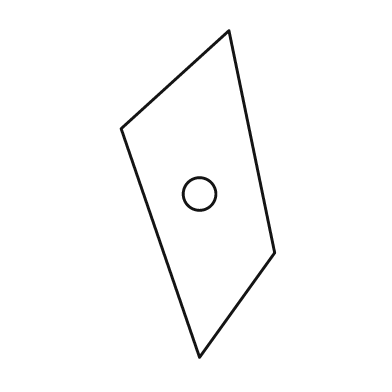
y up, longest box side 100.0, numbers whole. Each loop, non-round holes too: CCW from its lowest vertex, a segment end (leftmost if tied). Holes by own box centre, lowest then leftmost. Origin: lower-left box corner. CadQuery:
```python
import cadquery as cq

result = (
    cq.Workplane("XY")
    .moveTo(24.0, 0.0)
    .lineTo(47.0, 32.0)
    .lineTo(33.0, 100.0)
    .lineTo(0.0, 70.0)
    .close()
    .moveTo(24.0, 50.0)
    .circle(5.0)
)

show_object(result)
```